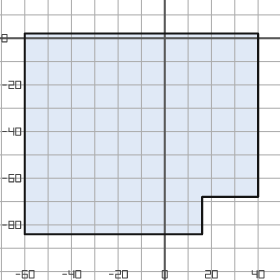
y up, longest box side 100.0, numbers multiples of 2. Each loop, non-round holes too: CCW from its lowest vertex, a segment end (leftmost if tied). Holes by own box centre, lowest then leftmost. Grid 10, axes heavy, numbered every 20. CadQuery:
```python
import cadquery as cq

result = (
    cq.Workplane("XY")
    .moveTo(-60.0, -84.0)
    .lineTo(16.0, -84.0)
    .lineTo(16.0, -68.0)
    .lineTo(40.0, -68.0)
    .lineTo(40.0, 2.0)
    .lineTo(-60.0, 2.0)
    .close()
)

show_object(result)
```